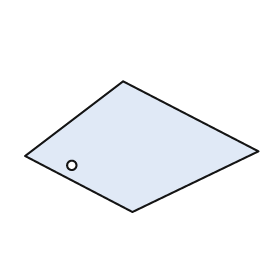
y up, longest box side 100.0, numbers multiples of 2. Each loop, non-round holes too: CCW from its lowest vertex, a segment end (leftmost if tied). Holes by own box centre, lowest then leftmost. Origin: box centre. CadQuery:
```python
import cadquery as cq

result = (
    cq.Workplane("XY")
    .moveTo(-4.0, -28.0)
    .lineTo(50.0, -2.0)
    .lineTo(-8.0, 28.0)
    .lineTo(-50.0, -4.0)
    .close()
    .moveTo(-30.0, -8.0)
    .circle(2.0)
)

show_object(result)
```